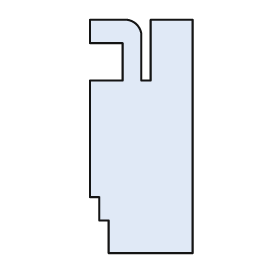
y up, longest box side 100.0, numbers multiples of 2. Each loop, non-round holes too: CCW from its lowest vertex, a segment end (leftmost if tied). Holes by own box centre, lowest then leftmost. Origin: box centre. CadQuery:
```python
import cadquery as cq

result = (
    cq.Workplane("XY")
    .moveTo(-14.0, -50.0)
    .lineTo(22.0, -50.0)
    .lineTo(22.0, 50.0)
    .lineTo(4.0, 50.0)
    .lineTo(4.0, 24.0)
    .lineTo(0.0, 24.0)
    .lineTo(0.0, 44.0)
    .threePointArc((-2.0, 48.0), (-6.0, 50.0))
    .lineTo(-22.0, 50.0)
    .lineTo(-22.0, 40.0)
    .lineTo(-8.0, 40.0)
    .lineTo(-8.0, 24.0)
    .lineTo(-22.0, 24.0)
    .lineTo(-22.0, -26.0)
    .lineTo(-18.0, -26.0)
    .lineTo(-18.0, -36.0)
    .lineTo(-14.0, -36.0)
    .close()
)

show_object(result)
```